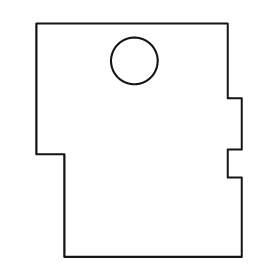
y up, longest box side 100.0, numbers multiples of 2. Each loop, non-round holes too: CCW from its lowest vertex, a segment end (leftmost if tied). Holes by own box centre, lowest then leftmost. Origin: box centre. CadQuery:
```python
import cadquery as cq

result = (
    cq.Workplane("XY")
    .moveTo(-32.0, -50.0)
    .lineTo(44.0, -50.0)
    .lineTo(44.0, -16.0)
    .lineTo(38.0, -16.0)
    .lineTo(38.0, -4.0)
    .lineTo(44.0, -4.0)
    .lineTo(44.0, 18.0)
    .lineTo(38.0, 18.0)
    .lineTo(38.0, 50.0)
    .lineTo(-44.0, 50.0)
    .lineTo(-44.0, -6.0)
    .lineTo(-32.0, -6.0)
    .close()
    .moveTo(-2.0, 34.0)
    .circle(10.0)
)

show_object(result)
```